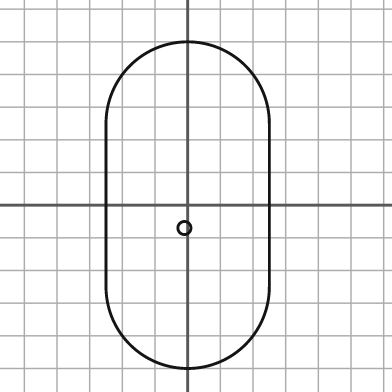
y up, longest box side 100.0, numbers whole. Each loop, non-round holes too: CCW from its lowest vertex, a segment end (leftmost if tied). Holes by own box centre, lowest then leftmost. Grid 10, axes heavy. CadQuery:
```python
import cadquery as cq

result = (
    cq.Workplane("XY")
    .moveTo(-25.0, -25.0)
    .threePointArc((0.0, -50.0), (25.0, -25.0))
    .lineTo(25.0, 25.0)
    .threePointArc((0.0, 50.0), (-25.0, 25.0))
    .close()
    .moveTo(-1.0, -7.0)
    .circle(2.0)
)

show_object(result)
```